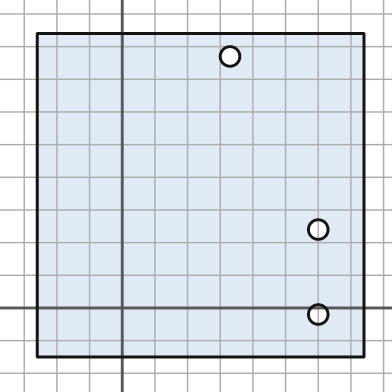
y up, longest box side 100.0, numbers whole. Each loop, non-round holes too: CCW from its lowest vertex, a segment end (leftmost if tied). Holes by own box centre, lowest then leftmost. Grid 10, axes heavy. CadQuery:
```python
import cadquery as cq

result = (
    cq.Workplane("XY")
    .moveTo(-26.0, -15.0)
    .lineTo(74.0, -15.0)
    .lineTo(74.0, 84.0)
    .lineTo(-26.0, 84.0)
    .close()
    .moveTo(60.0, -2.0)
    .circle(3.0)
    .moveTo(60.0, 24.0)
    .circle(3.0)
    .moveTo(33.0, 77.0)
    .circle(3.0)
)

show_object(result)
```